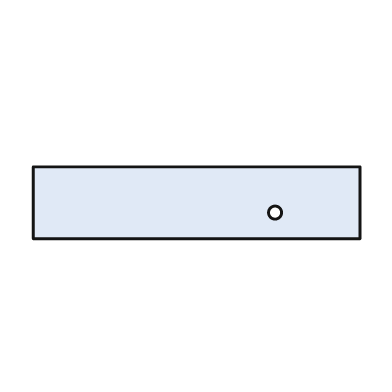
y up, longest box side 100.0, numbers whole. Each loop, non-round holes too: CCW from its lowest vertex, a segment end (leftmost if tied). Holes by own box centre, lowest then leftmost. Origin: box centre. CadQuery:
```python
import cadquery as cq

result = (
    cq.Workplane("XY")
    .moveTo(-50.0, -11.0)
    .lineTo(50.0, -11.0)
    .lineTo(50.0, 11.0)
    .lineTo(-50.0, 11.0)
    .close()
    .moveTo(24.0, -3.0)
    .circle(2.0)
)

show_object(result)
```